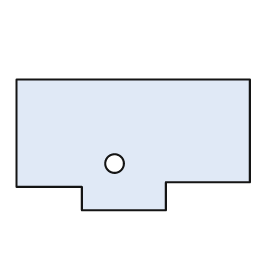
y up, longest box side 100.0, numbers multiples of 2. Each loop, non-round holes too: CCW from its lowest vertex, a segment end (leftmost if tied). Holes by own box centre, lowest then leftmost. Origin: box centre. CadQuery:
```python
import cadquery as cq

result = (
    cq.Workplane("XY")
    .moveTo(-22.0, -28.0)
    .lineTo(14.0, -28.0)
    .lineTo(14.0, -16.0)
    .lineTo(50.0, -16.0)
    .lineTo(50.0, 28.0)
    .lineTo(-50.0, 28.0)
    .lineTo(-50.0, -18.0)
    .lineTo(-22.0, -18.0)
    .close()
    .moveTo(-8.0, -8.0)
    .circle(4.0)
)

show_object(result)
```